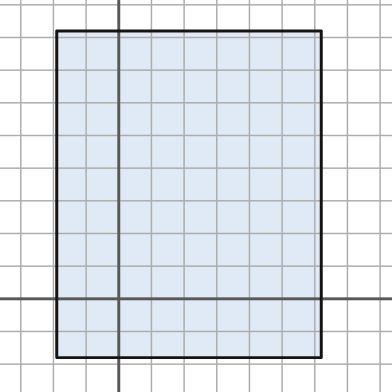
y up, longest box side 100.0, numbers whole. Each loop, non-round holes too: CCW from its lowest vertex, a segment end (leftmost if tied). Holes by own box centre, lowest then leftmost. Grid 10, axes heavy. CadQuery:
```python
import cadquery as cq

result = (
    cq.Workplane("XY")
    .moveTo(-19.0, -18.0)
    .lineTo(62.0, -18.0)
    .lineTo(62.0, 82.0)
    .lineTo(-19.0, 82.0)
    .close()
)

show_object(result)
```